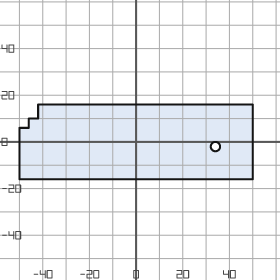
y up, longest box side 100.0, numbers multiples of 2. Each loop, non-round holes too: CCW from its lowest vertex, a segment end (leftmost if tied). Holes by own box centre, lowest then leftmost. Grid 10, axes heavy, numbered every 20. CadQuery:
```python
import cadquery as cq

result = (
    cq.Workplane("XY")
    .moveTo(-50.0, -16.0)
    .lineTo(50.0, -16.0)
    .lineTo(50.0, 16.0)
    .lineTo(-42.0, 16.0)
    .lineTo(-42.0, 10.0)
    .lineTo(-46.0, 10.0)
    .lineTo(-46.0, 6.0)
    .lineTo(-50.0, 6.0)
    .close()
    .moveTo(34.0, -2.0)
    .circle(2.0)
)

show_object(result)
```